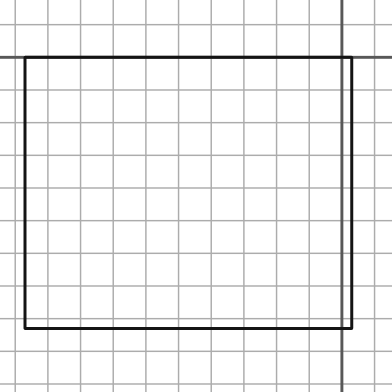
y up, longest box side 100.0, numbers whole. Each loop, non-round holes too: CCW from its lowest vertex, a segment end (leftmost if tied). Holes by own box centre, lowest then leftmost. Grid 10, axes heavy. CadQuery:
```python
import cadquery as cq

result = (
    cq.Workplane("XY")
    .moveTo(-97.0, -83.0)
    .lineTo(3.0, -83.0)
    .lineTo(3.0, 0.0)
    .lineTo(-97.0, 0.0)
    .close()
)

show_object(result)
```